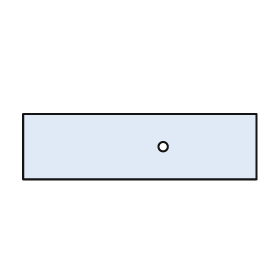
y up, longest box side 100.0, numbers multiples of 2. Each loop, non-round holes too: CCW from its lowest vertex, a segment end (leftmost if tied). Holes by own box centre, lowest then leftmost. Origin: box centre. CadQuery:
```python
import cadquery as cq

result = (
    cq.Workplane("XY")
    .moveTo(-50.0, -14.0)
    .lineTo(50.0, -14.0)
    .lineTo(50.0, 14.0)
    .lineTo(-50.0, 14.0)
    .close()
    .moveTo(10.0, 0.0)
    .circle(2.0)
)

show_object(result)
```